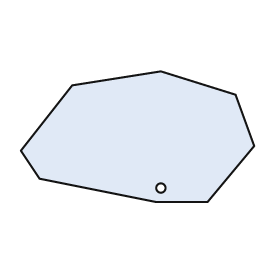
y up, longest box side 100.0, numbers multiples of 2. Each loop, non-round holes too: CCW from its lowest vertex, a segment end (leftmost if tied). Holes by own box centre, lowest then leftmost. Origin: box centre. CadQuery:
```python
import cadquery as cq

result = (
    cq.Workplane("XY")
    .moveTo(8.0, -28.0)
    .lineTo(30.0, -28.0)
    .lineTo(50.0, -4.0)
    .lineTo(42.0, 18.0)
    .lineTo(10.0, 28.0)
    .lineTo(-28.0, 22.0)
    .lineTo(-50.0, -6.0)
    .lineTo(-42.0, -18.0)
    .close()
    .moveTo(10.0, -22.0)
    .circle(2.0)
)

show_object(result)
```